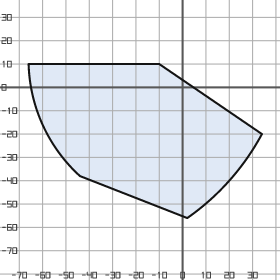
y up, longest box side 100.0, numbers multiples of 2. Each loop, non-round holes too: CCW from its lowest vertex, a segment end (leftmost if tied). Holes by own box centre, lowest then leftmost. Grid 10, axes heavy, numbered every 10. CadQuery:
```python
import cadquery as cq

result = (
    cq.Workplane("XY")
    .moveTo(2.0, -56.0)
    .threePointArc((20.0, -40.0), (34.0, -20.0))
    .lineTo(-10.0, 10.0)
    .lineTo(-66.0, 10.0)
    .threePointArc((-60.0, -16.0), (-44.0, -38.0))
    .close()
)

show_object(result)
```